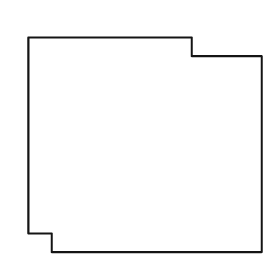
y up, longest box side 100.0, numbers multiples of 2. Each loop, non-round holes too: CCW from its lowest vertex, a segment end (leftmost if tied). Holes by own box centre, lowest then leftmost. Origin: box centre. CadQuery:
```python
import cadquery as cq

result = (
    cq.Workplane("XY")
    .moveTo(-40.0, -46.0)
    .lineTo(50.0, -46.0)
    .lineTo(50.0, 38.0)
    .lineTo(20.0, 38.0)
    .lineTo(20.0, 46.0)
    .lineTo(-50.0, 46.0)
    .lineTo(-50.0, -38.0)
    .lineTo(-40.0, -38.0)
    .close()
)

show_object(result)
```